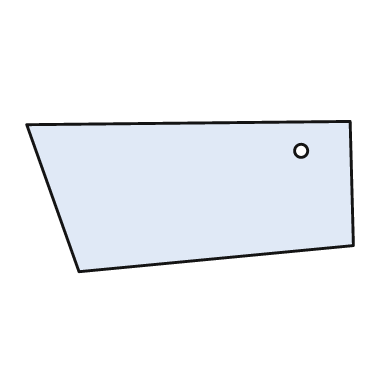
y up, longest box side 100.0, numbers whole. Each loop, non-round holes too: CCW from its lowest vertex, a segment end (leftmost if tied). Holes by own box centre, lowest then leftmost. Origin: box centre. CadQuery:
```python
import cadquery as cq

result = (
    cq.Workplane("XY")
    .moveTo(-34.0, -23.0)
    .lineTo(50.0, -15.0)
    .lineTo(49.0, 23.0)
    .lineTo(-50.0, 22.0)
    .close()
    .moveTo(34.0, 14.0)
    .circle(2.0)
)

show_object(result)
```